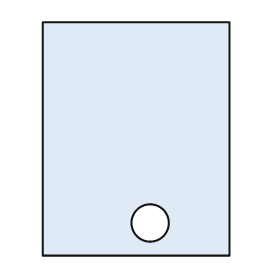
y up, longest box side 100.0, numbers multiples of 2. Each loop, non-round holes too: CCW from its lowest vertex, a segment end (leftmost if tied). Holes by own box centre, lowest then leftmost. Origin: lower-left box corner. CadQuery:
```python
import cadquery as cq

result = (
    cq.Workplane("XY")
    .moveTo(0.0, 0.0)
    .lineTo(80.0, 0.0)
    .lineTo(80.0, 100.0)
    .lineTo(0.0, 100.0)
    .close()
    .moveTo(46.0, 14.0)
    .circle(8.0)
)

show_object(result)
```